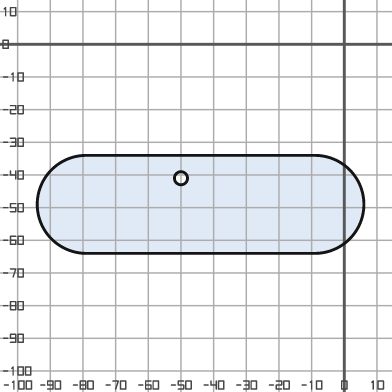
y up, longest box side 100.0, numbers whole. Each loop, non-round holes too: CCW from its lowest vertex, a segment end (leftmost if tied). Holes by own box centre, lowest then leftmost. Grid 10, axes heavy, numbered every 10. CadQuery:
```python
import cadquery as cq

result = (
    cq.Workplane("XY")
    .moveTo(-79.0, -64.0)
    .lineTo(-9.0, -64.0)
    .threePointArc((6.0, -49.0), (-9.0, -34.0))
    .lineTo(-79.0, -34.0)
    .threePointArc((-94.0, -49.0), (-79.0, -64.0))
    .close()
    .moveTo(-50.0, -41.0)
    .circle(2.0)
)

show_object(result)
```